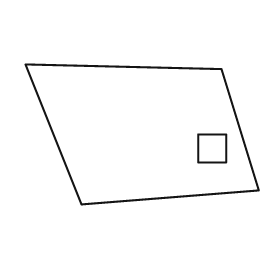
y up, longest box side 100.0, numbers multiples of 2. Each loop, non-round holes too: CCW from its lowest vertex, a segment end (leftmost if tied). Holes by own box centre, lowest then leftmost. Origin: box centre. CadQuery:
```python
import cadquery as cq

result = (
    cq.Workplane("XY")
    .moveTo(-26.0, -30.0)
    .lineTo(50.0, -24.0)
    .lineTo(34.0, 28.0)
    .lineTo(-50.0, 30.0)
    .close()
    .moveTo(24.0, -12.0)
    .lineTo(36.0, -12.0)
    .lineTo(36.0, 0.0)
    .lineTo(24.0, 0.0)
    .close()
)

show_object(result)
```